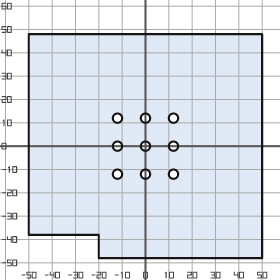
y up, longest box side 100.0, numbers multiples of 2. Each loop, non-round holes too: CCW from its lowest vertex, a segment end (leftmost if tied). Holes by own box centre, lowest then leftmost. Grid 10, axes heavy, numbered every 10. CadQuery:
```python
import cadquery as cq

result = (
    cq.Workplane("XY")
    .moveTo(-20.0, -48.0)
    .lineTo(50.0, -48.0)
    .lineTo(50.0, 48.0)
    .lineTo(-50.0, 48.0)
    .lineTo(-50.0, -38.0)
    .lineTo(-20.0, -38.0)
    .close()
    .moveTo(-12.0, -12.0)
    .circle(2.0)
    .moveTo(0.0, -12.0)
    .circle(2.0)
    .moveTo(12.0, -12.0)
    .circle(2.0)
    .moveTo(-12.0, 0.0)
    .circle(2.0)
    .moveTo(0.0, 0.0)
    .circle(2.0)
    .moveTo(12.0, 0.0)
    .circle(2.0)
    .moveTo(-12.0, 12.0)
    .circle(2.0)
    .moveTo(0.0, 12.0)
    .circle(2.0)
    .moveTo(12.0, 12.0)
    .circle(2.0)
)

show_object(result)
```